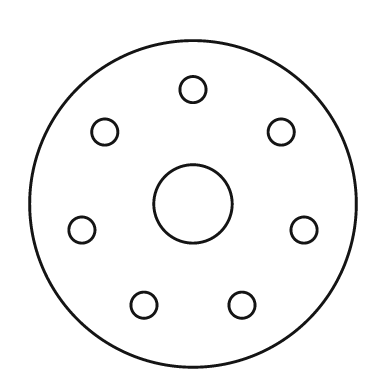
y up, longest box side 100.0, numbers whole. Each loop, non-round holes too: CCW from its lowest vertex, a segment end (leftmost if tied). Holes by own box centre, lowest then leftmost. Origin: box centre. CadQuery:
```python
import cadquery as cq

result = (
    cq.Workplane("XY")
    .moveTo(0.0, 0.0)
    .circle(50.0)
    .moveTo(-15.0, -31.0)
    .circle(4.0)
    .moveTo(15.0, -31.0)
    .circle(4.0)
    .moveTo(-34.0, -8.0)
    .circle(4.0)
    .moveTo(34.0, -8.0)
    .circle(4.0)
    .moveTo(0.0, 0.0)
    .circle(12.0)
    .moveTo(-27.0, 22.0)
    .circle(4.0)
    .moveTo(27.0, 22.0)
    .circle(4.0)
    .moveTo(0.0, 35.0)
    .circle(4.0)
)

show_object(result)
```